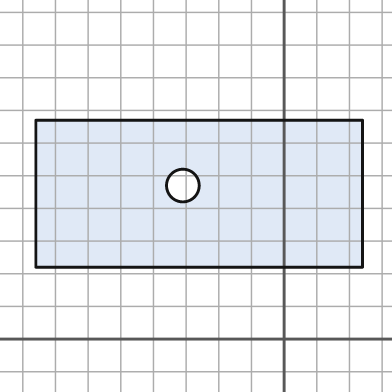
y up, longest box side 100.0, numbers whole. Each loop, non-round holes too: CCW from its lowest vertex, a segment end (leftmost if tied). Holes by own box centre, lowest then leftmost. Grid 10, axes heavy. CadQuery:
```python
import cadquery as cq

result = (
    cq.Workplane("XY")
    .moveTo(-76.0, 22.0)
    .lineTo(24.0, 22.0)
    .lineTo(24.0, 67.0)
    .lineTo(-76.0, 67.0)
    .close()
    .moveTo(-31.0, 47.0)
    .circle(5.0)
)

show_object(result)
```